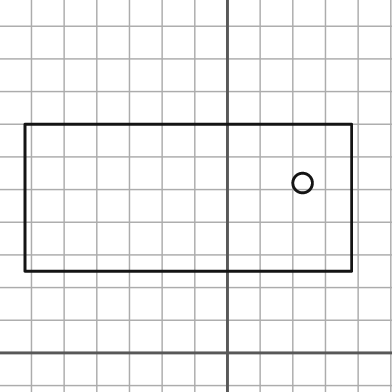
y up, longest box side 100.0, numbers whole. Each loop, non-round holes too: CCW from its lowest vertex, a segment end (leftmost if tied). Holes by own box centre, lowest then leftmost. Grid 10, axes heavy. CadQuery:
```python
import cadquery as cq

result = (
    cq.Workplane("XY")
    .moveTo(-62.0, 25.0)
    .lineTo(38.0, 25.0)
    .lineTo(38.0, 70.0)
    .lineTo(-62.0, 70.0)
    .close()
    .moveTo(23.0, 52.0)
    .circle(3.0)
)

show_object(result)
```